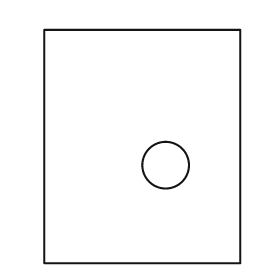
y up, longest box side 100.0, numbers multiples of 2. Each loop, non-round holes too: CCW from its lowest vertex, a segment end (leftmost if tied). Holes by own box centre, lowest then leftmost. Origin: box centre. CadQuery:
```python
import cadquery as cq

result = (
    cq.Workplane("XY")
    .moveTo(-42.0, -50.0)
    .lineTo(42.0, -50.0)
    .lineTo(42.0, 50.0)
    .lineTo(-42.0, 50.0)
    .close()
    .moveTo(10.0, -8.0)
    .circle(10.0)
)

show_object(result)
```